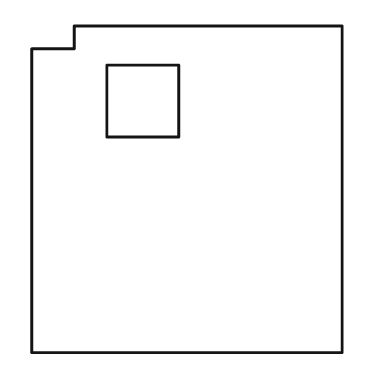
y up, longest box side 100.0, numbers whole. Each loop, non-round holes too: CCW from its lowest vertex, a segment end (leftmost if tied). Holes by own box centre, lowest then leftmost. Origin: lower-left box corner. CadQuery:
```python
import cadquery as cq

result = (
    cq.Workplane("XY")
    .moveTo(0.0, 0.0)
    .lineTo(95.0, 0.0)
    .lineTo(95.0, 100.0)
    .lineTo(13.0, 100.0)
    .lineTo(13.0, 93.0)
    .lineTo(0.0, 93.0)
    .close()
    .moveTo(23.0, 66.0)
    .lineTo(45.0, 66.0)
    .lineTo(45.0, 88.0)
    .lineTo(23.0, 88.0)
    .close()
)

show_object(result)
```